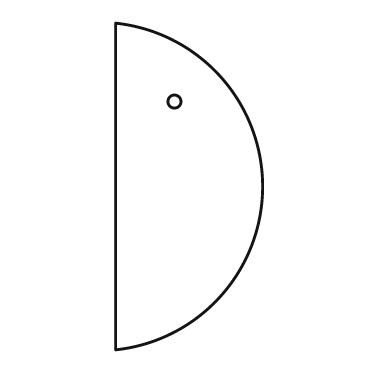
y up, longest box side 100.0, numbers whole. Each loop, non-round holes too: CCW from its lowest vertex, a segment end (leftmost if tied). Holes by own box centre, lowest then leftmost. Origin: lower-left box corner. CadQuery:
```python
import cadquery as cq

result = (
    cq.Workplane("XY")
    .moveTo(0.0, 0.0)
    .threePointArc((45.0, 50.0), (0.0, 100.0))
    .close()
    .moveTo(18.0, 76.0)
    .circle(2.0)
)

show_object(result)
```